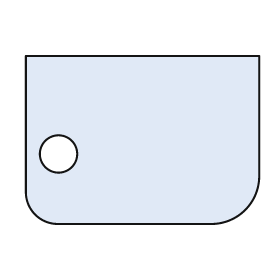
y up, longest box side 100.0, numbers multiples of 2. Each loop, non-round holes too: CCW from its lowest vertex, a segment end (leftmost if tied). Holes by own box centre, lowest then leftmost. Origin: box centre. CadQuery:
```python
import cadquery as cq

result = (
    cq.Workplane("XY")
    .moveTo(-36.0, -36.0)
    .lineTo(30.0, -36.0)
    .threePointArc((44.0, -30.0), (50.0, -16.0))
    .lineTo(50.0, 36.0)
    .lineTo(-50.0, 36.0)
    .lineTo(-50.0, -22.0)
    .threePointArc((-46.0, -32.0), (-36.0, -36.0))
    .close()
    .moveTo(-36.0, -6.0)
    .circle(8.0)
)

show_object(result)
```